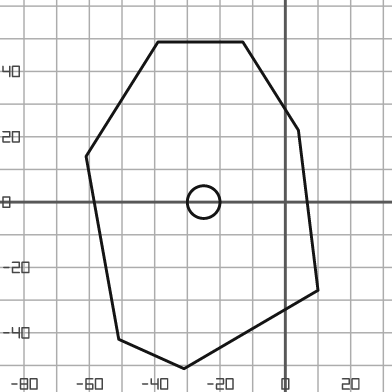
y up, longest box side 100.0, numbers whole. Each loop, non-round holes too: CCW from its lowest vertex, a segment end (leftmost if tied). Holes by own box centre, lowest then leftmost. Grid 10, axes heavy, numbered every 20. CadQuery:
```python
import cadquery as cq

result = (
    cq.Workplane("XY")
    .moveTo(-31.0, -51.0)
    .lineTo(10.0, -27.0)
    .lineTo(4.0, 22.0)
    .lineTo(-13.0, 49.0)
    .lineTo(-39.0, 49.0)
    .lineTo(-61.0, 14.0)
    .lineTo(-51.0, -42.0)
    .close()
    .moveTo(-25.0, 0.0)
    .circle(5.0)
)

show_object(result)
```